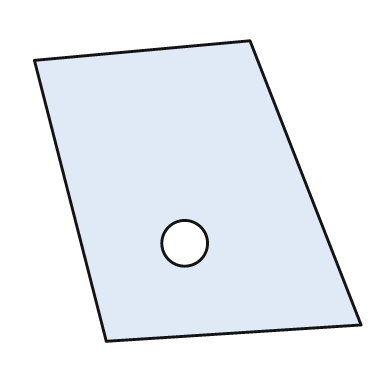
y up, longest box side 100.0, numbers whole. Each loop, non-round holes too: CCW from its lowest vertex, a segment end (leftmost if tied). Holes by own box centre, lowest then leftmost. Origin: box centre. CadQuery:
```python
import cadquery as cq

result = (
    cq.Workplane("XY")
    .moveTo(-28.0, -46.0)
    .lineTo(50.0, -41.0)
    .lineTo(16.0, 46.0)
    .lineTo(-50.0, 40.0)
    .close()
    .moveTo(-4.0, -16.0)
    .circle(7.0)
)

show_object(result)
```